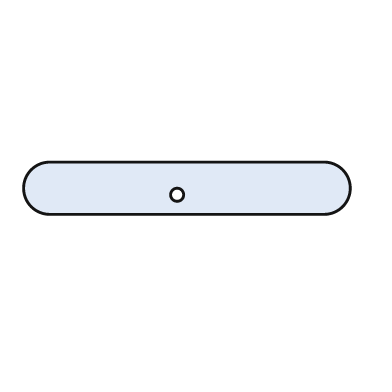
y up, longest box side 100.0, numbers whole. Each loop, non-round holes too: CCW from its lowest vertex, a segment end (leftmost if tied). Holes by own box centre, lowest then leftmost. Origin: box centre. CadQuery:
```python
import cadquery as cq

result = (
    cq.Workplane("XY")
    .moveTo(-42.0, -8.0)
    .lineTo(42.0, -8.0)
    .threePointArc((50.0, 0.0), (42.0, 8.0))
    .lineTo(-42.0, 8.0)
    .threePointArc((-50.0, 0.0), (-42.0, -8.0))
    .close()
    .moveTo(-3.0, -2.0)
    .circle(2.0)
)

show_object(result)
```